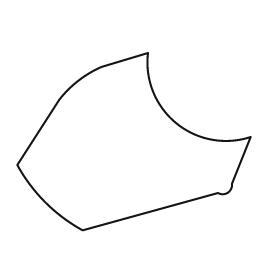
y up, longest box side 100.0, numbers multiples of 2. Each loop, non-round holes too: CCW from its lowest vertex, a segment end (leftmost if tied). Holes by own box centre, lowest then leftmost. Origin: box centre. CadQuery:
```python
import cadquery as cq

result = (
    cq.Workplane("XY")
    .moveTo(-22.0, -38.0)
    .lineTo(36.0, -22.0)
    .threePointArc((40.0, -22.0), (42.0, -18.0))
    .lineTo(50.0, 2.0)
    .threePointArc((18.0, 8.0), (6.0, 38.0))
    .lineTo(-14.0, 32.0)
    .threePointArc((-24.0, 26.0), (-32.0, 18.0))
    .lineTo(-50.0, -10.0)
    .threePointArc((-38.0, -26.0), (-22.0, -38.0))
    .close()
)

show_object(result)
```